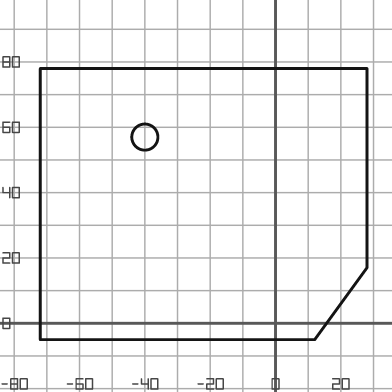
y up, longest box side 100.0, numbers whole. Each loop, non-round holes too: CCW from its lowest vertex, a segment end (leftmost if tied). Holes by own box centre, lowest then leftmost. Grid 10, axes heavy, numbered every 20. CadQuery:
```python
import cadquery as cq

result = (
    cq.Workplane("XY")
    .moveTo(-72.0, -5.0)
    .lineTo(12.0, -5.0)
    .lineTo(28.0, 17.0)
    .lineTo(28.0, 78.0)
    .lineTo(-72.0, 78.0)
    .close()
    .moveTo(-40.0, 57.0)
    .circle(4.0)
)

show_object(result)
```